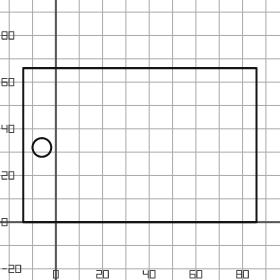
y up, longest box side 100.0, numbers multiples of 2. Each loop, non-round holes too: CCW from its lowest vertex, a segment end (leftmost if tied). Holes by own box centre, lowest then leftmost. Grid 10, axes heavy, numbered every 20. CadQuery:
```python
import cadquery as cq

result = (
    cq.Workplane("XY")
    .moveTo(-14.0, 0.0)
    .lineTo(86.0, 0.0)
    .lineTo(86.0, 66.0)
    .lineTo(-14.0, 66.0)
    .close()
    .moveTo(-6.0, 32.0)
    .circle(4.0)
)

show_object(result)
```